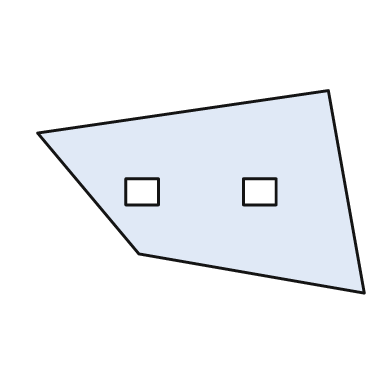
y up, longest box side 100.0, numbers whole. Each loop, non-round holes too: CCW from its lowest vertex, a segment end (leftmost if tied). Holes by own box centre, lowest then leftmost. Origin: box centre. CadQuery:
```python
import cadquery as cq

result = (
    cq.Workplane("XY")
    .moveTo(50.0, -31.0)
    .lineTo(39.0, 31.0)
    .lineTo(-50.0, 18.0)
    .lineTo(-19.0, -19.0)
    .close()
    .moveTo(-23.0, -4.0)
    .lineTo(-13.0, -4.0)
    .lineTo(-13.0, 4.0)
    .lineTo(-23.0, 4.0)
    .close()
    .moveTo(13.0, -4.0)
    .lineTo(23.0, -4.0)
    .lineTo(23.0, 4.0)
    .lineTo(13.0, 4.0)
    .close()
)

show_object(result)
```